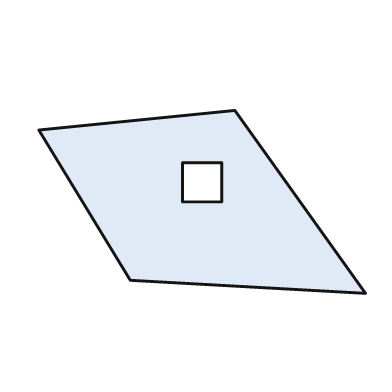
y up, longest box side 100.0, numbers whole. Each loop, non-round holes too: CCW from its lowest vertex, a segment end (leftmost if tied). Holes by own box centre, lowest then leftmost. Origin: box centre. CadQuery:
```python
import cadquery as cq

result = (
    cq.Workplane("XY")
    .moveTo(50.0, -28.0)
    .lineTo(10.0, 28.0)
    .lineTo(-50.0, 22.0)
    .lineTo(-22.0, -24.0)
    .close()
    .moveTo(-6.0, 0.0)
    .lineTo(6.0, 0.0)
    .lineTo(6.0, 12.0)
    .lineTo(-6.0, 12.0)
    .close()
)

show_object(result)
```